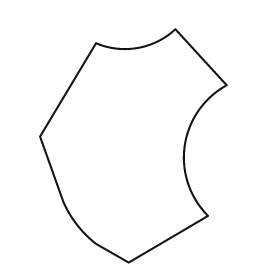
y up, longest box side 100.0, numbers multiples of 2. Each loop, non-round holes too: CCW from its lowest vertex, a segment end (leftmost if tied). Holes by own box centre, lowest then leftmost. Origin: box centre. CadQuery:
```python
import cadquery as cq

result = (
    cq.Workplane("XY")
    .moveTo(-2.0, -50.0)
    .lineTo(32.0, -30.0)
    .threePointArc((22.0, 0.0), (40.0, 26.0))
    .lineTo(18.0, 50.0)
    .threePointArc((2.0, 42.0), (-16.0, 44.0))
    .lineTo(-40.0, 4.0)
    .lineTo(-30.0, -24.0)
    .threePointArc((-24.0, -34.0), (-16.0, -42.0))
    .close()
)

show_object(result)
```